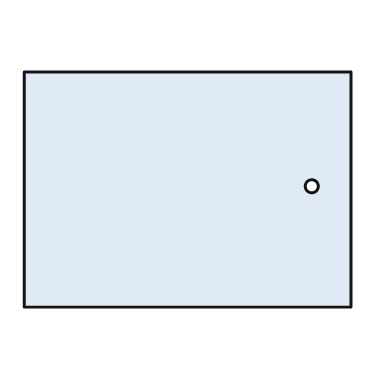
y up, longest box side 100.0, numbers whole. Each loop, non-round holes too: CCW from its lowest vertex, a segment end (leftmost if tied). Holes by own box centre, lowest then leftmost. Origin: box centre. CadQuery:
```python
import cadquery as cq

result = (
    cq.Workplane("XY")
    .moveTo(-50.0, -36.0)
    .lineTo(50.0, -36.0)
    .lineTo(50.0, 36.0)
    .lineTo(-50.0, 36.0)
    .close()
    .moveTo(38.0, 1.0)
    .circle(2.0)
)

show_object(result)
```